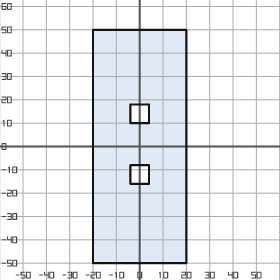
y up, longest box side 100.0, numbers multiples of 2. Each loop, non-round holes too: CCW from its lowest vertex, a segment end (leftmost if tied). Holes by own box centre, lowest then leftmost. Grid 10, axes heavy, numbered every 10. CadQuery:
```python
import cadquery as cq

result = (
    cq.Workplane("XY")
    .moveTo(-20.0, -50.0)
    .lineTo(20.0, -50.0)
    .lineTo(20.0, 50.0)
    .lineTo(-20.0, 50.0)
    .close()
    .moveTo(-4.0, -16.0)
    .lineTo(4.0, -16.0)
    .lineTo(4.0, -8.0)
    .lineTo(-4.0, -8.0)
    .close()
    .moveTo(-4.0, 10.0)
    .lineTo(4.0, 10.0)
    .lineTo(4.0, 18.0)
    .lineTo(-4.0, 18.0)
    .close()
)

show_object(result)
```